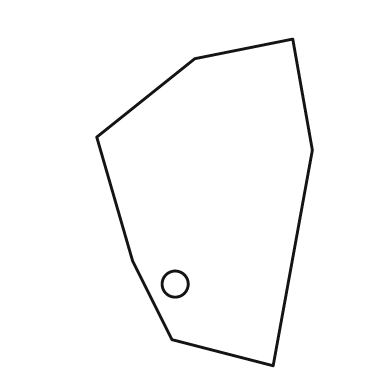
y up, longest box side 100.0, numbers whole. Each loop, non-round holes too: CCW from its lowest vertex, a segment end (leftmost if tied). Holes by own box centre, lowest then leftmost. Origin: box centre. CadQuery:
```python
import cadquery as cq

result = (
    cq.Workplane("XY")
    .moveTo(21.0, -50.0)
    .lineTo(33.0, 16.0)
    .lineTo(27.0, 50.0)
    .lineTo(-3.0, 44.0)
    .lineTo(-33.0, 20.0)
    .lineTo(-22.0, -18.0)
    .lineTo(-10.0, -42.0)
    .close()
    .moveTo(-9.0, -25.0)
    .circle(4.0)
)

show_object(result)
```